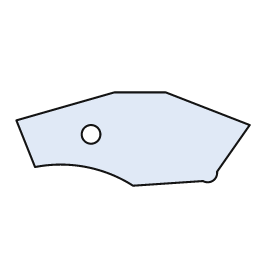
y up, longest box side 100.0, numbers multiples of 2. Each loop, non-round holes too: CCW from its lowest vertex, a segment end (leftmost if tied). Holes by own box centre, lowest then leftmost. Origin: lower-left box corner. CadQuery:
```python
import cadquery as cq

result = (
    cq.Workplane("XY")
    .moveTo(50.0, 0.0)
    .lineTo(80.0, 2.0)
    .threePointArc((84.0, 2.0), (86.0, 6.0))
    .lineTo(100.0, 26.0)
    .lineTo(64.0, 40.0)
    .lineTo(42.0, 40.0)
    .lineTo(0.0, 28.0)
    .lineTo(8.0, 8.0)
    .threePointArc((30.0, 8.0), (50.0, 0.0))
    .close()
    .moveTo(32.0, 22.0)
    .circle(4.0)
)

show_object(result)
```